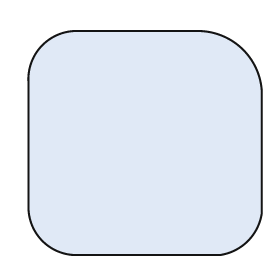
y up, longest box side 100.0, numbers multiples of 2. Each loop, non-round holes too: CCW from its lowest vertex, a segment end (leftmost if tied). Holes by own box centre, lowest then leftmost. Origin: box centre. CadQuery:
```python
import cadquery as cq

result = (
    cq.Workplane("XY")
    .moveTo(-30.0, -48.0)
    .lineTo(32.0, -48.0)
    .threePointArc((44.0, -42.0), (50.0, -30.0))
    .lineTo(50.0, 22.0)
    .threePointArc((42.0, 40.0), (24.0, 48.0))
    .lineTo(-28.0, 48.0)
    .threePointArc((-44.0, 42.0), (-50.0, 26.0))
    .lineTo(-50.0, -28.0)
    .threePointArc((-44.0, -42.0), (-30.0, -48.0))
    .close()
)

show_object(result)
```